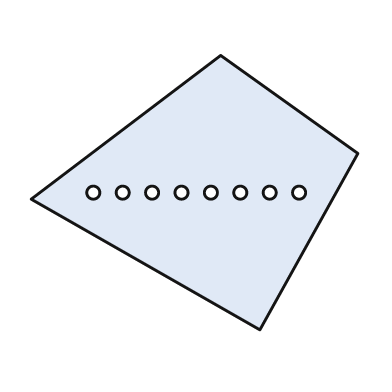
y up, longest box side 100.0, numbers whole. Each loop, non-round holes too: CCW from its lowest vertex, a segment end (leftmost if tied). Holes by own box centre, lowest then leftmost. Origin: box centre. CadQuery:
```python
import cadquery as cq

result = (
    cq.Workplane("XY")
    .moveTo(20.0, -42.0)
    .lineTo(50.0, 12.0)
    .lineTo(8.0, 42.0)
    .lineTo(-50.0, -2.0)
    .close()
    .moveTo(-31.0, 0.0)
    .circle(2.0)
    .moveTo(-22.0, 0.0)
    .circle(2.0)
    .moveTo(-13.0, 0.0)
    .circle(2.0)
    .moveTo(-4.0, 0.0)
    .circle(2.0)
    .moveTo(5.0, 0.0)
    .circle(2.0)
    .moveTo(14.0, 0.0)
    .circle(2.0)
    .moveTo(23.0, 0.0)
    .circle(2.0)
    .moveTo(32.0, 0.0)
    .circle(2.0)
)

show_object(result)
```